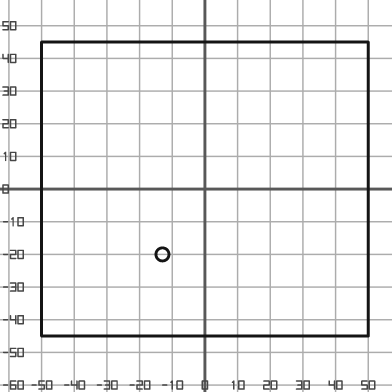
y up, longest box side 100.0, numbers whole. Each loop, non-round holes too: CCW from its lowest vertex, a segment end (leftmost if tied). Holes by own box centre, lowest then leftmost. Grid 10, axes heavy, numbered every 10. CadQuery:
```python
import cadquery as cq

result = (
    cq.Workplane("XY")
    .moveTo(-50.0, -45.0)
    .lineTo(50.0, -45.0)
    .lineTo(50.0, 45.0)
    .lineTo(-50.0, 45.0)
    .close()
    .moveTo(-13.0, -20.0)
    .circle(2.0)
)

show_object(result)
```